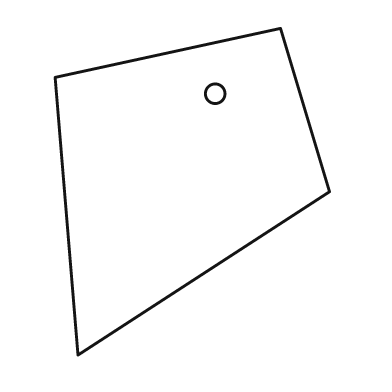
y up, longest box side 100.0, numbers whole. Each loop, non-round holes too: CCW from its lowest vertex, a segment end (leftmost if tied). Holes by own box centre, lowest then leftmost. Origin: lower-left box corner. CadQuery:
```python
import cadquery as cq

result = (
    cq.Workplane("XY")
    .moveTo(7.0, 0.0)
    .lineTo(84.0, 50.0)
    .lineTo(69.0, 100.0)
    .lineTo(0.0, 85.0)
    .close()
    .moveTo(49.0, 80.0)
    .circle(3.0)
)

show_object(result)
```